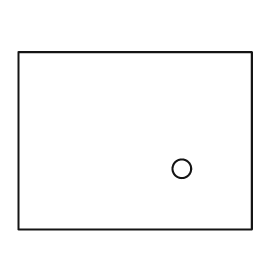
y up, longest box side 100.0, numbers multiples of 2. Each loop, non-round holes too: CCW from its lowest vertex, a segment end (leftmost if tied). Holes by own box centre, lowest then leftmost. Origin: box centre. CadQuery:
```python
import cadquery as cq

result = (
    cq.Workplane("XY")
    .moveTo(-50.0, -38.0)
    .lineTo(50.0, -38.0)
    .lineTo(50.0, 38.0)
    .lineTo(-50.0, 38.0)
    .close()
    .moveTo(20.0, -12.0)
    .circle(4.0)
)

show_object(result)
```